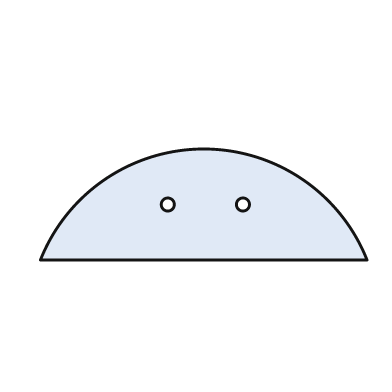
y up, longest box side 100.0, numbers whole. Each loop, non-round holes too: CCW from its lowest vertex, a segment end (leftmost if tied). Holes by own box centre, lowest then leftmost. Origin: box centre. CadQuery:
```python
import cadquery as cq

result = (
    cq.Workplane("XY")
    .moveTo(-50.0, -17.0)
    .lineTo(50.0, -17.0)
    .threePointArc((0.0, 17.0), (-50.0, -17.0))
    .close()
    .moveTo(-11.0, 0.0)
    .circle(2.0)
    .moveTo(12.0, 0.0)
    .circle(2.0)
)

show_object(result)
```